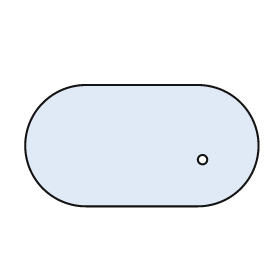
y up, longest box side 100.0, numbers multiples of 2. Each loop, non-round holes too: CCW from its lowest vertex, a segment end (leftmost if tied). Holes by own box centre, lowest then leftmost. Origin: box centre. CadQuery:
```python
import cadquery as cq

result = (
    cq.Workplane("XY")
    .moveTo(-24.0, -26.0)
    .lineTo(24.0, -26.0)
    .threePointArc((50.0, 0.0), (24.0, 26.0))
    .lineTo(-24.0, 26.0)
    .threePointArc((-50.0, 0.0), (-24.0, -26.0))
    .close()
    .moveTo(26.0, -6.0)
    .circle(2.0)
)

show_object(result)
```